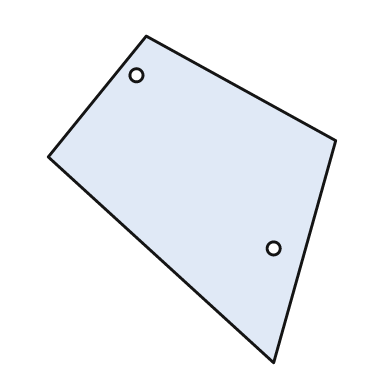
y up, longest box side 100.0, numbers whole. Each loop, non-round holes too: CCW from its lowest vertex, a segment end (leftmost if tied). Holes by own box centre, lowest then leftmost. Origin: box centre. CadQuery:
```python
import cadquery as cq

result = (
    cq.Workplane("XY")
    .moveTo(25.0, -50.0)
    .lineTo(44.0, 18.0)
    .lineTo(-14.0, 50.0)
    .lineTo(-44.0, 13.0)
    .close()
    .moveTo(25.0, -15.0)
    .circle(2.0)
    .moveTo(-17.0, 38.0)
    .circle(2.0)
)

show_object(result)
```